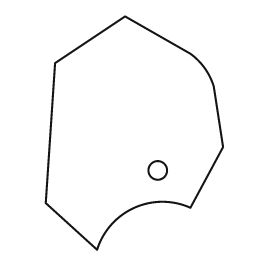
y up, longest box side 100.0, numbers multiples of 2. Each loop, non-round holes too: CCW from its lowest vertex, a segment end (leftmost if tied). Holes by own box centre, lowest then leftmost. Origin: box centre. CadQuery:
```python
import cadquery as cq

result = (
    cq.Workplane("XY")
    .moveTo(-16.0, -50.0)
    .threePointArc((0.0, -32.0), (24.0, -32.0))
    .lineTo(38.0, -6.0)
    .lineTo(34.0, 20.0)
    .threePointArc((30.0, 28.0), (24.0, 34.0))
    .lineTo(-4.0, 50.0)
    .lineTo(-34.0, 30.0)
    .lineTo(-38.0, -30.0)
    .close()
    .moveTo(10.0, -16.0)
    .circle(4.0)
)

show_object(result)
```